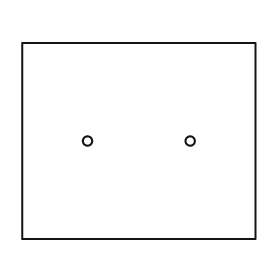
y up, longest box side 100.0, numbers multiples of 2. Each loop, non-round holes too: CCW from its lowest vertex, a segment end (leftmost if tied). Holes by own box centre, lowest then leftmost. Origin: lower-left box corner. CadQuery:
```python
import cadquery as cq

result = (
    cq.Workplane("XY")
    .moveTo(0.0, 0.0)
    .lineTo(100.0, 0.0)
    .lineTo(100.0, 84.0)
    .lineTo(0.0, 84.0)
    .close()
    .moveTo(28.0, 42.0)
    .circle(2.0)
    .moveTo(72.0, 42.0)
    .circle(2.0)
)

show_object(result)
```